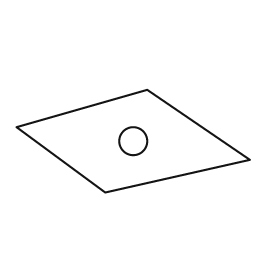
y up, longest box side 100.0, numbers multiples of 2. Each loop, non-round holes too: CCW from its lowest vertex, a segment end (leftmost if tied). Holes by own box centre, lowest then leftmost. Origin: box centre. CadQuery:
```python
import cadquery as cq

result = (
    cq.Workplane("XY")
    .moveTo(-12.0, -22.0)
    .lineTo(50.0, -8.0)
    .lineTo(6.0, 22.0)
    .lineTo(-50.0, 6.0)
    .close()
    .moveTo(0.0, 0.0)
    .circle(6.0)
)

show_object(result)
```